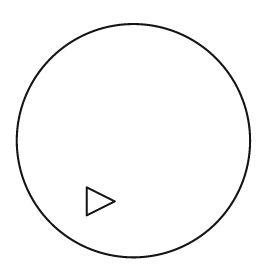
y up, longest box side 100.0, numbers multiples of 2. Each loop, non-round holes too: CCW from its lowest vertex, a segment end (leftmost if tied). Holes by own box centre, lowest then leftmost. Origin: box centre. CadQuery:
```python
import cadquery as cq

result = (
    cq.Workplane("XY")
    .moveTo(0.0, 0.0)
    .circle(50.0)
    .moveTo(-20.0, -32.0)
    .lineTo(-8.0, -26.0)
    .lineTo(-20.0, -20.0)
    .close()
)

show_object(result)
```